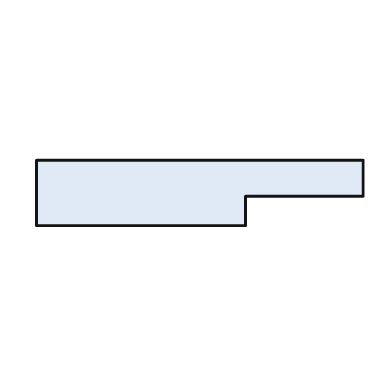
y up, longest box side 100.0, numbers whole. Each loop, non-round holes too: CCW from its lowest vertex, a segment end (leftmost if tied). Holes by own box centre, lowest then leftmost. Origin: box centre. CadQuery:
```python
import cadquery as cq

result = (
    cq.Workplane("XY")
    .moveTo(-50.0, -10.0)
    .lineTo(14.0, -10.0)
    .lineTo(14.0, -1.0)
    .lineTo(50.0, -1.0)
    .lineTo(50.0, 10.0)
    .lineTo(-50.0, 10.0)
    .close()
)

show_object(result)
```